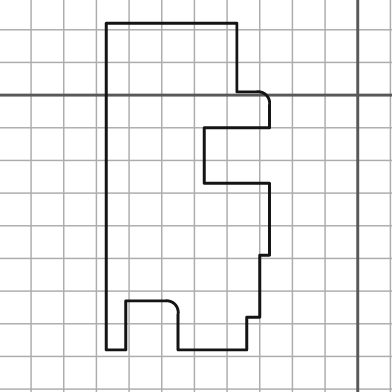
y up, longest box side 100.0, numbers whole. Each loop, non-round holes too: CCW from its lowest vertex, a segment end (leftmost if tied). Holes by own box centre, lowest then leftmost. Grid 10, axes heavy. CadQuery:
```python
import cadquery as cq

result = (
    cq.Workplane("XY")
    .moveTo(-77.0, -78.0)
    .lineTo(-71.0, -78.0)
    .lineTo(-71.0, -63.0)
    .lineTo(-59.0, -63.0)
    .threePointArc((-56.0, -64.0), (-55.0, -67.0))
    .lineTo(-55.0, -78.0)
    .lineTo(-34.0, -78.0)
    .lineTo(-34.0, -68.0)
    .lineTo(-30.0, -68.0)
    .lineTo(-30.0, -49.0)
    .lineTo(-27.0, -49.0)
    .lineTo(-27.0, -27.0)
    .lineTo(-47.0, -27.0)
    .lineTo(-47.0, -10.0)
    .lineTo(-27.0, -10.0)
    .lineTo(-27.0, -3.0)
    .threePointArc((-28.0, 0.0), (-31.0, 1.0))
    .lineTo(-37.0, 1.0)
    .lineTo(-37.0, 22.0)
    .lineTo(-77.0, 22.0)
    .close()
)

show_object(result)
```